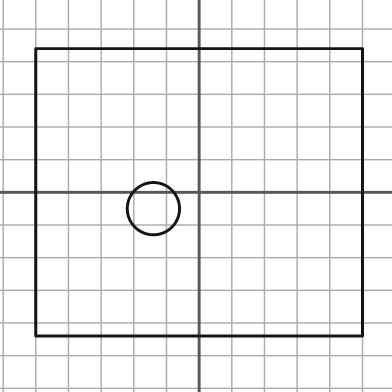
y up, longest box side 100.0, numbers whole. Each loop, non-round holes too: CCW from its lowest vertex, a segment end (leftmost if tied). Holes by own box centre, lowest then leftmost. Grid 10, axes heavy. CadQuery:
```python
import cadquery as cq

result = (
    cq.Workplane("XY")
    .moveTo(-50.0, -44.0)
    .lineTo(50.0, -44.0)
    .lineTo(50.0, 44.0)
    .lineTo(-50.0, 44.0)
    .close()
    .moveTo(-14.0, -5.0)
    .circle(8.0)
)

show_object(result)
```